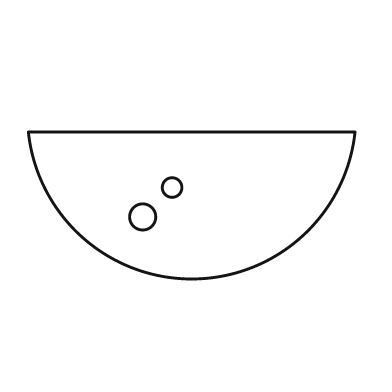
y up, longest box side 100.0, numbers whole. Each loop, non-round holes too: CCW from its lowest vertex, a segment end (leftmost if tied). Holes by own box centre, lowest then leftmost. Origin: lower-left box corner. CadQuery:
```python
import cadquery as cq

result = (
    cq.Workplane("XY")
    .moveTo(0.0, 45.0)
    .threePointArc((50.0, 0.0), (100.0, 45.0))
    .close()
    .moveTo(35.0, 19.0)
    .circle(4.0)
    .moveTo(44.0, 28.0)
    .circle(3.0)
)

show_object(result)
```